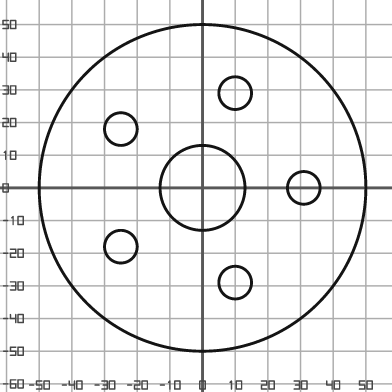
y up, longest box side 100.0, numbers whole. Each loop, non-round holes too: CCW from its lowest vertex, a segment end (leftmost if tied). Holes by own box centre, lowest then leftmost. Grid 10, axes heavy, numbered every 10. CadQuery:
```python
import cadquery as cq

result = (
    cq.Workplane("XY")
    .moveTo(0.0, 0.0)
    .circle(50.0)
    .moveTo(10.0, -29.0)
    .circle(5.0)
    .moveTo(-25.0, -18.0)
    .circle(5.0)
    .moveTo(0.0, 0.0)
    .circle(13.0)
    .moveTo(31.0, 0.0)
    .circle(5.0)
    .moveTo(-25.0, 18.0)
    .circle(5.0)
    .moveTo(10.0, 29.0)
    .circle(5.0)
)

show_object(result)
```